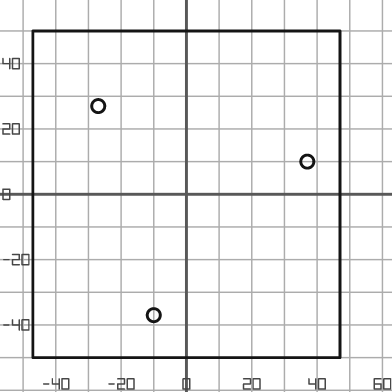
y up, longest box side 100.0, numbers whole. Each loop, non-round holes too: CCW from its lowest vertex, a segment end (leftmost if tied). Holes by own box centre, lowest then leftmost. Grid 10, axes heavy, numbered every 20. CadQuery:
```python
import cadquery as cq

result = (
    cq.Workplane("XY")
    .moveTo(-47.0, -50.0)
    .lineTo(47.0, -50.0)
    .lineTo(47.0, 50.0)
    .lineTo(-47.0, 50.0)
    .close()
    .moveTo(-10.0, -37.0)
    .circle(2.0)
    .moveTo(37.0, 10.0)
    .circle(2.0)
    .moveTo(-27.0, 27.0)
    .circle(2.0)
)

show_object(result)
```